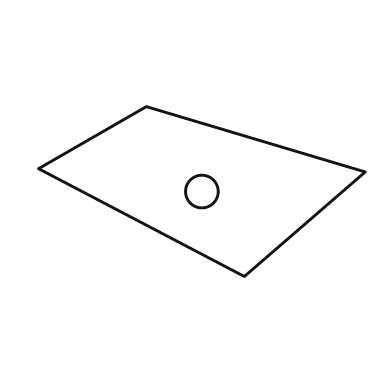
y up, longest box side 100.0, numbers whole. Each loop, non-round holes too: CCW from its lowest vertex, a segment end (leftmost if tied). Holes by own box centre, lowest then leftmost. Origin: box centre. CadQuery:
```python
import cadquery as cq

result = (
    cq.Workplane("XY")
    .moveTo(13.0, -26.0)
    .lineTo(50.0, 6.0)
    .lineTo(-17.0, 26.0)
    .lineTo(-50.0, 7.0)
    .close()
    .moveTo(0.0, 0.0)
    .circle(5.0)
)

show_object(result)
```